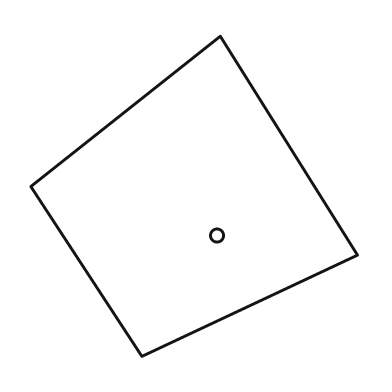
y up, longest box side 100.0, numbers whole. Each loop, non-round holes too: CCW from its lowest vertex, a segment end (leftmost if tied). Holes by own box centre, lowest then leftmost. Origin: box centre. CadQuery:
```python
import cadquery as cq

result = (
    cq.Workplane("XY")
    .moveTo(-16.0, -49.0)
    .lineTo(50.0, -18.0)
    .lineTo(8.0, 49.0)
    .lineTo(-50.0, 3.0)
    .close()
    .moveTo(7.0, -12.0)
    .circle(2.0)
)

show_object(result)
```